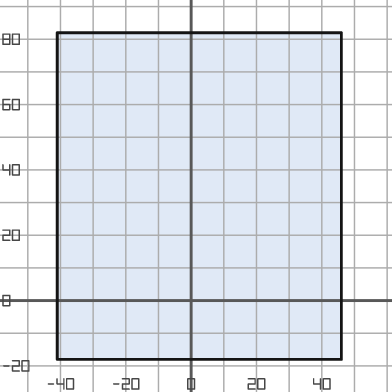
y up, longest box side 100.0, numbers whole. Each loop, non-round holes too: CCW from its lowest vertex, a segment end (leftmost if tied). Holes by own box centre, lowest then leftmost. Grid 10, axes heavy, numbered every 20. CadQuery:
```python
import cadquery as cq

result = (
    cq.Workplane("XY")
    .moveTo(-41.0, -18.0)
    .lineTo(46.0, -18.0)
    .lineTo(46.0, 82.0)
    .lineTo(-41.0, 82.0)
    .close()
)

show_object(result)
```